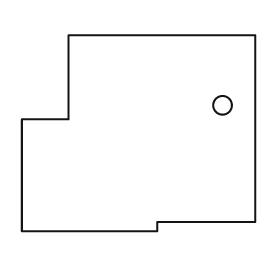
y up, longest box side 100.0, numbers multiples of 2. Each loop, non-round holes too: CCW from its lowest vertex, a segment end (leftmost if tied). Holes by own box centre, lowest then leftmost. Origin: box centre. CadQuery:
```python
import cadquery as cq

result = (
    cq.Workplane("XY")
    .moveTo(-50.0, -42.0)
    .lineTo(8.0, -42.0)
    .lineTo(8.0, -38.0)
    .lineTo(50.0, -38.0)
    .lineTo(50.0, 42.0)
    .lineTo(-30.0, 42.0)
    .lineTo(-30.0, 6.0)
    .lineTo(-50.0, 6.0)
    .close()
    .moveTo(36.0, 12.0)
    .circle(4.0)
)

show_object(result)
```